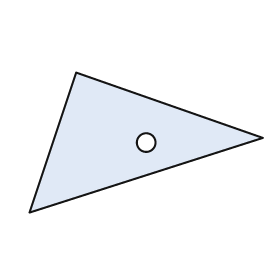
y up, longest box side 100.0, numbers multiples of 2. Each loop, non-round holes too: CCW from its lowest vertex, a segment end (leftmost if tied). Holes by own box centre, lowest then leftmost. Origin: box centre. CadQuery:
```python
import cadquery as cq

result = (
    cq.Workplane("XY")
    .moveTo(-50.0, -30.0)
    .lineTo(50.0, 2.0)
    .lineTo(-30.0, 30.0)
    .close()
    .moveTo(0.0, 0.0)
    .circle(4.0)
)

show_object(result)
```